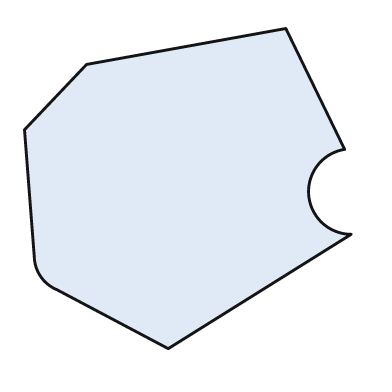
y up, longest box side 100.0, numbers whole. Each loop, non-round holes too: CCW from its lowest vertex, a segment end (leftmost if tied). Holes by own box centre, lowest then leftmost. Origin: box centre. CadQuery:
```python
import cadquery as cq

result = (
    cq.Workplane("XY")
    .moveTo(-6.0, -49.0)
    .lineTo(50.0, -14.0)
    .threePointArc((37.0, -2.0), (48.0, 12.0))
    .lineTo(30.0, 49.0)
    .lineTo(-31.0, 38.0)
    .lineTo(-50.0, 18.0)
    .lineTo(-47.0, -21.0)
    .threePointArc((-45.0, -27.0), (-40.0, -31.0))
    .close()
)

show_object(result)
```